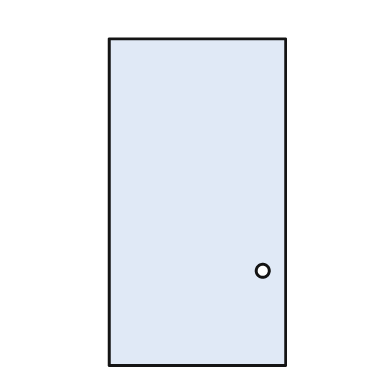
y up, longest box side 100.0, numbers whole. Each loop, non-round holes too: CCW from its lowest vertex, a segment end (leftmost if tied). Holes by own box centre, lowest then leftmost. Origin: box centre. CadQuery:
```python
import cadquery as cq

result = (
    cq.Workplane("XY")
    .moveTo(-27.0, -50.0)
    .lineTo(27.0, -50.0)
    .lineTo(27.0, 50.0)
    .lineTo(-27.0, 50.0)
    .close()
    .moveTo(20.0, -21.0)
    .circle(2.0)
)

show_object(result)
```